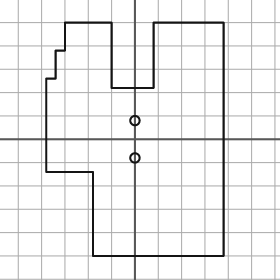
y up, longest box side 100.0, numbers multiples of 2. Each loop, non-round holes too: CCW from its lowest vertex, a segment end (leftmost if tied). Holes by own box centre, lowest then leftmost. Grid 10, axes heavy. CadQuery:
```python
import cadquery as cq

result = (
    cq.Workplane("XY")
    .moveTo(-18.0, -50.0)
    .lineTo(38.0, -50.0)
    .lineTo(38.0, 50.0)
    .lineTo(8.0, 50.0)
    .lineTo(8.0, 22.0)
    .lineTo(-10.0, 22.0)
    .lineTo(-10.0, 50.0)
    .lineTo(-30.0, 50.0)
    .lineTo(-30.0, 38.0)
    .lineTo(-34.0, 38.0)
    .lineTo(-34.0, 26.0)
    .lineTo(-38.0, 26.0)
    .lineTo(-38.0, -14.0)
    .lineTo(-18.0, -14.0)
    .close()
    .moveTo(0.0, -8.0)
    .circle(2.0)
    .moveTo(0.0, 8.0)
    .circle(2.0)
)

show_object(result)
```